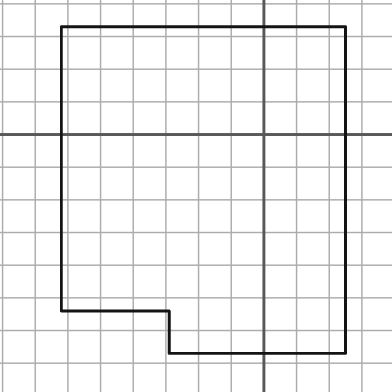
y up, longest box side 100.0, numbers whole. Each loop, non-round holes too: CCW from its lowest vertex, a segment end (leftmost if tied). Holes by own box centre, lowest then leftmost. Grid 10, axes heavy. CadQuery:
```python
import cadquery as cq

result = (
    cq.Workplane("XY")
    .moveTo(-29.0, -67.0)
    .lineTo(25.0, -67.0)
    .lineTo(25.0, 33.0)
    .lineTo(-62.0, 33.0)
    .lineTo(-62.0, -54.0)
    .lineTo(-29.0, -54.0)
    .close()
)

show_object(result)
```